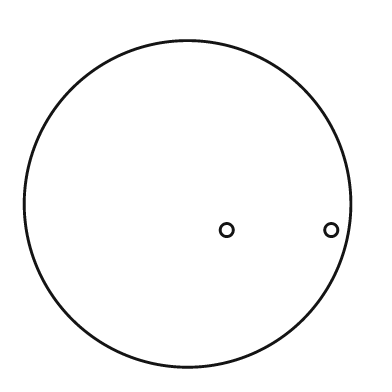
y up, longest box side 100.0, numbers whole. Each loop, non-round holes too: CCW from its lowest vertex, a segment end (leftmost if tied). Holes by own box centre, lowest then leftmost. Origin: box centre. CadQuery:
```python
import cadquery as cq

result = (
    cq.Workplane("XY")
    .moveTo(0.0, 0.0)
    .circle(50.0)
    .moveTo(12.0, -8.0)
    .circle(2.0)
    .moveTo(44.0, -8.0)
    .circle(2.0)
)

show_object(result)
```